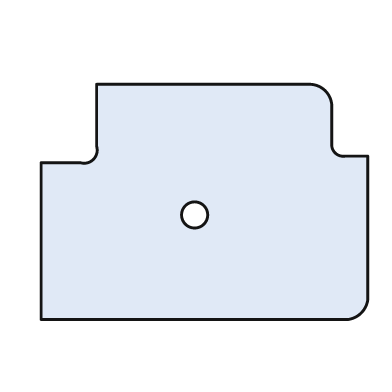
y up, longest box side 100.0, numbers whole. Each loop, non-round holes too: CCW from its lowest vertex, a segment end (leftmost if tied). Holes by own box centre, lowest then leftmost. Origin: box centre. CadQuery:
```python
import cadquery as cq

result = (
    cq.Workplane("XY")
    .moveTo(-50.0, -36.0)
    .lineTo(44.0, -36.0)
    .threePointArc((48.0, -34.0), (50.0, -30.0))
    .lineTo(50.0, 14.0)
    .lineTo(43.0, 14.0)
    .threePointArc((40.0, 15.0), (39.0, 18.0))
    .lineTo(39.0, 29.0)
    .threePointArc((37.0, 34.0), (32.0, 36.0))
    .lineTo(-33.0, 36.0)
    .lineTo(-33.0, 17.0)
    .threePointArc((-34.0, 13.0), (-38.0, 12.0))
    .lineTo(-50.0, 12.0)
    .close()
    .moveTo(-3.0, -4.0)
    .circle(4.0)
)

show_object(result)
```